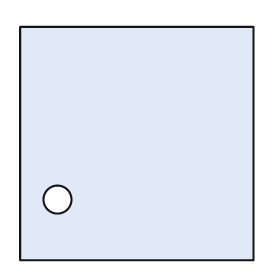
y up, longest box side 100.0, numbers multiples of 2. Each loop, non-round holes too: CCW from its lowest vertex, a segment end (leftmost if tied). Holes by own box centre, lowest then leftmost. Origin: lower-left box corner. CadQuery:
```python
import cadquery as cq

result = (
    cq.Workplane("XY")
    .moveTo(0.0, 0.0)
    .lineTo(100.0, 0.0)
    .lineTo(100.0, 100.0)
    .lineTo(0.0, 100.0)
    .close()
    .moveTo(16.0, 26.0)
    .circle(6.0)
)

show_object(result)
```